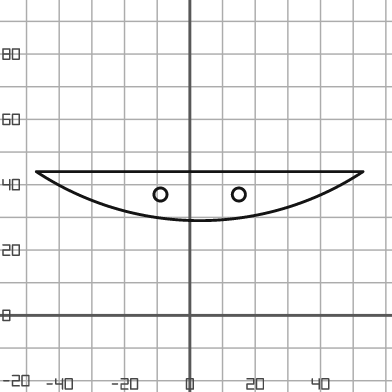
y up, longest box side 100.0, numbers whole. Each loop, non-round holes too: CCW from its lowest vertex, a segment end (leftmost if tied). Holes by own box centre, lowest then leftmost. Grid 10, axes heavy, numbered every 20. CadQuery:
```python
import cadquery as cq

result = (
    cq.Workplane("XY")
    .moveTo(-47.0, 44.0)
    .threePointArc((3.0, 29.0), (53.0, 44.0))
    .close()
    .moveTo(-9.0, 37.0)
    .circle(2.0)
    .moveTo(15.0, 37.0)
    .circle(2.0)
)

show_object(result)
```